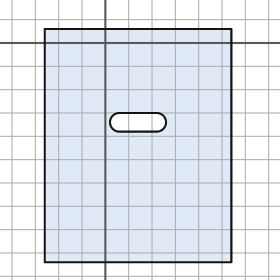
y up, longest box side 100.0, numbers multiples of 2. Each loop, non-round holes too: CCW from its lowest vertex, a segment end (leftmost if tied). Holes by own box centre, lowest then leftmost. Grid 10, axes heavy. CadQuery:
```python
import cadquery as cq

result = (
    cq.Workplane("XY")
    .moveTo(-26.0, -94.0)
    .lineTo(54.0, -94.0)
    .lineTo(54.0, 6.0)
    .lineTo(-26.0, 6.0)
    .close()
    .moveTo(6.0, -38.0)
    .lineTo(22.0, -38.0)
    .threePointArc((26.0, -34.0), (22.0, -30.0))
    .lineTo(6.0, -30.0)
    .threePointArc((2.0, -34.0), (6.0, -38.0))
    .close()
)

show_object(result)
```